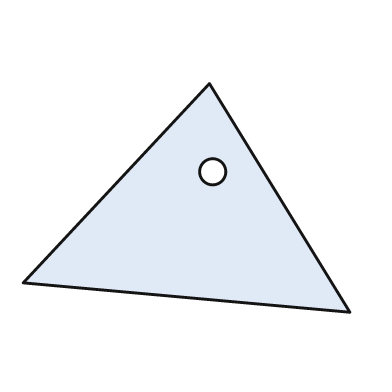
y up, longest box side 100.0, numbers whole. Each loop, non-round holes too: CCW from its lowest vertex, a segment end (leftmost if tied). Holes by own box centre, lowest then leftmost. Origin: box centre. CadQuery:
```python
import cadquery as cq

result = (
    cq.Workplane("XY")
    .moveTo(50.0, -35.0)
    .lineTo(7.0, 35.0)
    .lineTo(-50.0, -26.0)
    .close()
    .moveTo(8.0, 8.0)
    .circle(4.0)
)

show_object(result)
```